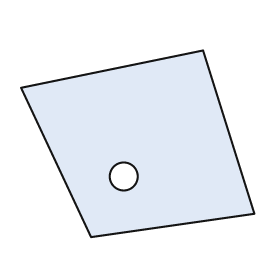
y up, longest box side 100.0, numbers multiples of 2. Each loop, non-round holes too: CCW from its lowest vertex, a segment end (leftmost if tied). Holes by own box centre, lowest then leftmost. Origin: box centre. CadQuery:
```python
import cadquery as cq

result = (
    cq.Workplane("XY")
    .moveTo(-20.0, -40.0)
    .lineTo(50.0, -30.0)
    .lineTo(28.0, 40.0)
    .lineTo(-50.0, 24.0)
    .close()
    .moveTo(-6.0, -14.0)
    .circle(6.0)
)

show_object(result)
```